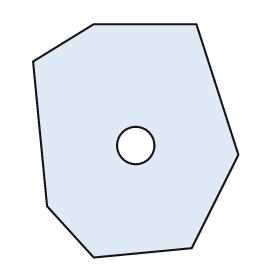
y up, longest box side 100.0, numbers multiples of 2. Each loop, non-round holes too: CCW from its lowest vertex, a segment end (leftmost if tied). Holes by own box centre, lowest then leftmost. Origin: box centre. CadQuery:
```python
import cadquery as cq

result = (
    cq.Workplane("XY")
    .moveTo(-18.0, -50.0)
    .lineTo(24.0, -46.0)
    .lineTo(44.0, -6.0)
    .lineTo(26.0, 50.0)
    .lineTo(-18.0, 50.0)
    .lineTo(-44.0, 34.0)
    .lineTo(-38.0, -28.0)
    .close()
    .moveTo(0.0, -2.0)
    .circle(8.0)
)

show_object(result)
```